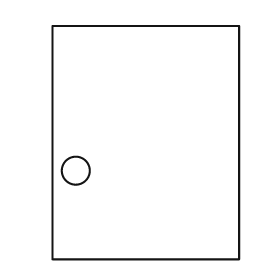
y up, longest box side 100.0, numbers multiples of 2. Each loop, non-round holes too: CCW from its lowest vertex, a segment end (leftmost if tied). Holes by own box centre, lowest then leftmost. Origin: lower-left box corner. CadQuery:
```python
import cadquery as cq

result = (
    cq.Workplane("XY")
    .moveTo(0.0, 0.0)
    .lineTo(80.0, 0.0)
    .lineTo(80.0, 100.0)
    .lineTo(0.0, 100.0)
    .close()
    .moveTo(10.0, 38.0)
    .circle(6.0)
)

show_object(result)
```